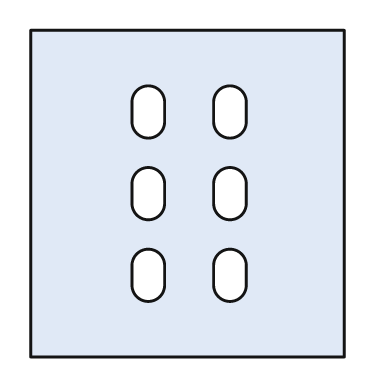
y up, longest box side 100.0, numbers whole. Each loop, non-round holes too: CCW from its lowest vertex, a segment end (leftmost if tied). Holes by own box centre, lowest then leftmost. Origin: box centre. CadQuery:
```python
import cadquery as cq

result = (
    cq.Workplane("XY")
    .moveTo(-48.0, -50.0)
    .lineTo(48.0, -50.0)
    .lineTo(48.0, 50.0)
    .lineTo(-48.0, 50.0)
    .close()
    .moveTo(-17.0, -28.0)
    .threePointArc((-12.0, -33.0), (-7.0, -28.0))
    .lineTo(-7.0, -22.0)
    .threePointArc((-12.0, -17.0), (-17.0, -22.0))
    .close()
    .moveTo(8.0, -28.0)
    .threePointArc((13.0, -33.0), (18.0, -28.0))
    .lineTo(18.0, -22.0)
    .threePointArc((13.0, -17.0), (8.0, -22.0))
    .close()
    .moveTo(-17.0, -3.0)
    .threePointArc((-12.0, -8.0), (-7.0, -3.0))
    .lineTo(-7.0, 3.0)
    .threePointArc((-12.0, 8.0), (-17.0, 3.0))
    .close()
    .moveTo(8.0, -3.0)
    .threePointArc((13.0, -8.0), (18.0, -3.0))
    .lineTo(18.0, 3.0)
    .threePointArc((13.0, 8.0), (8.0, 3.0))
    .close()
    .moveTo(-17.0, 22.0)
    .threePointArc((-12.0, 17.0), (-7.0, 22.0))
    .lineTo(-7.0, 28.0)
    .threePointArc((-12.0, 33.0), (-17.0, 28.0))
    .close()
    .moveTo(8.0, 22.0)
    .threePointArc((13.0, 17.0), (18.0, 22.0))
    .lineTo(18.0, 28.0)
    .threePointArc((13.0, 33.0), (8.0, 28.0))
    .close()
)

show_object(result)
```